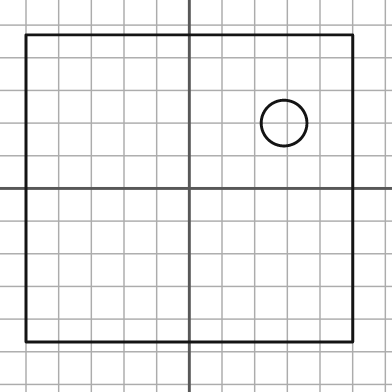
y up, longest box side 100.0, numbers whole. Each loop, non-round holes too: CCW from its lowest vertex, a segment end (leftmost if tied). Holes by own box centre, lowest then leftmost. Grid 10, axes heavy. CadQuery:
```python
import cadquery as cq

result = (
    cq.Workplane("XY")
    .moveTo(-50.0, -47.0)
    .lineTo(50.0, -47.0)
    .lineTo(50.0, 47.0)
    .lineTo(-50.0, 47.0)
    .close()
    .moveTo(29.0, 20.0)
    .circle(7.0)
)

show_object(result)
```